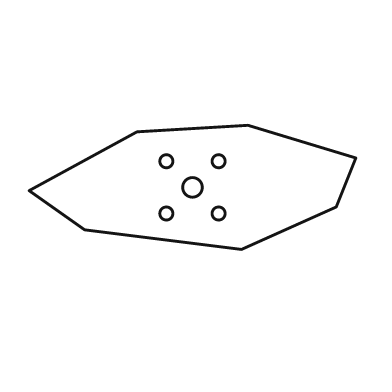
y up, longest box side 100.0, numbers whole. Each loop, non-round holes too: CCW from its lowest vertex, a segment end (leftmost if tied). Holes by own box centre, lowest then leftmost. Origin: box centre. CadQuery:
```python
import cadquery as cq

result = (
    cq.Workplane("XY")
    .moveTo(15.0, -19.0)
    .lineTo(44.0, -6.0)
    .lineTo(50.0, 9.0)
    .lineTo(17.0, 19.0)
    .lineTo(-17.0, 17.0)
    .lineTo(-50.0, -1.0)
    .lineTo(-33.0, -13.0)
    .close()
    .moveTo(-8.0, -8.0)
    .circle(2.0)
    .moveTo(8.0, -8.0)
    .circle(2.0)
    .moveTo(0.0, 0.0)
    .circle(3.0)
    .moveTo(-8.0, 8.0)
    .circle(2.0)
    .moveTo(8.0, 8.0)
    .circle(2.0)
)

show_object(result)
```